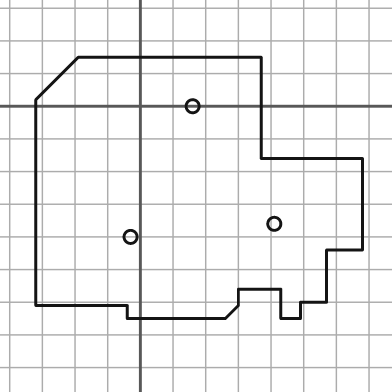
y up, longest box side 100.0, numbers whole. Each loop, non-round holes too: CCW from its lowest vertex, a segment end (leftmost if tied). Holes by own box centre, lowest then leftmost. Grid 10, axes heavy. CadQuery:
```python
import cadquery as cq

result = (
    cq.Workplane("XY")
    .moveTo(-4.0, -65.0)
    .lineTo(26.0, -65.0)
    .lineTo(30.0, -61.0)
    .lineTo(30.0, -56.0)
    .lineTo(43.0, -56.0)
    .lineTo(43.0, -65.0)
    .lineTo(49.0, -65.0)
    .lineTo(49.0, -60.0)
    .lineTo(57.0, -60.0)
    .lineTo(57.0, -44.0)
    .lineTo(68.0, -44.0)
    .lineTo(68.0, -16.0)
    .lineTo(37.0, -16.0)
    .lineTo(37.0, 15.0)
    .lineTo(-19.0, 15.0)
    .lineTo(-32.0, 2.0)
    .lineTo(-32.0, -61.0)
    .lineTo(-4.0, -61.0)
    .close()
    .moveTo(-3.0, -40.0)
    .circle(2.0)
    .moveTo(41.0, -36.0)
    .circle(2.0)
    .moveTo(16.0, 0.0)
    .circle(2.0)
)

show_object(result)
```